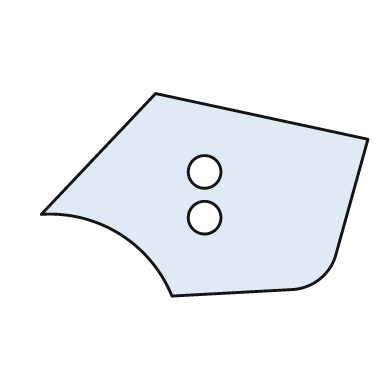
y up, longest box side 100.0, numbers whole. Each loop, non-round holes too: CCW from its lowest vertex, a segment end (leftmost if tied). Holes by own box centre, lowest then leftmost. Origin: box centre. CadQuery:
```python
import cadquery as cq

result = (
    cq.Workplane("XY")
    .moveTo(-10.0, -31.0)
    .lineTo(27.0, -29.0)
    .threePointArc((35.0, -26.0), (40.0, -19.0))
    .lineTo(50.0, 17.0)
    .lineTo(-15.0, 31.0)
    .lineTo(-50.0, -6.0)
    .threePointArc((-26.0, -12.0), (-10.0, -31.0))
    .close()
    .moveTo(0.0, -7.0)
    .circle(5.0)
    .moveTo(0.0, 7.0)
    .circle(5.0)
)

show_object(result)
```